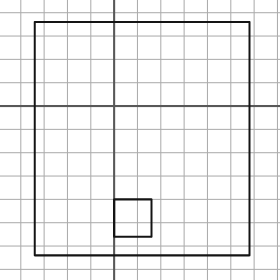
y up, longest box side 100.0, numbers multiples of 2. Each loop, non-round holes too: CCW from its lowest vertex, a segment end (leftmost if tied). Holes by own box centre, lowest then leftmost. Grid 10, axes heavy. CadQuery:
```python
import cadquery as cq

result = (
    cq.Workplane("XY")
    .moveTo(-34.0, -64.0)
    .lineTo(58.0, -64.0)
    .lineTo(58.0, 36.0)
    .lineTo(-34.0, 36.0)
    .close()
    .moveTo(0.0, -56.0)
    .lineTo(16.0, -56.0)
    .lineTo(16.0, -40.0)
    .lineTo(0.0, -40.0)
    .close()
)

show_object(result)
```